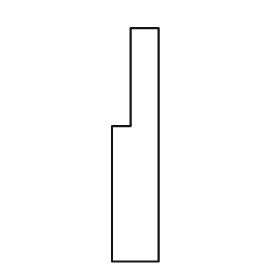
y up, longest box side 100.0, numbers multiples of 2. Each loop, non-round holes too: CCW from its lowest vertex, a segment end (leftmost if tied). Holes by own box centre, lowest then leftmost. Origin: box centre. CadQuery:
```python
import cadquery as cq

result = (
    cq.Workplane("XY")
    .moveTo(-10.0, -50.0)
    .lineTo(10.0, -50.0)
    .lineTo(10.0, 50.0)
    .lineTo(-2.0, 50.0)
    .lineTo(-2.0, 8.0)
    .lineTo(-10.0, 8.0)
    .close()
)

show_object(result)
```